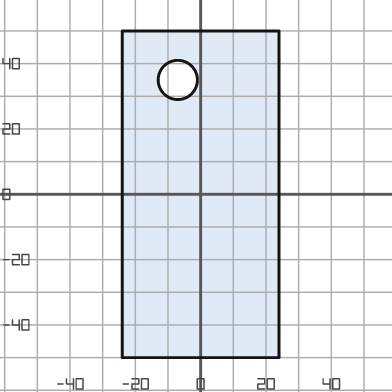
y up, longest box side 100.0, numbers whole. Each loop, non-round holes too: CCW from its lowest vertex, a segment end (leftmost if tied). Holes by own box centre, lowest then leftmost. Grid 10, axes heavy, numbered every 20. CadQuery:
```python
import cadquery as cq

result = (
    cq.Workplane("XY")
    .moveTo(-24.0, -50.0)
    .lineTo(24.0, -50.0)
    .lineTo(24.0, 50.0)
    .lineTo(-24.0, 50.0)
    .close()
    .moveTo(-7.0, 35.0)
    .circle(6.0)
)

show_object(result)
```